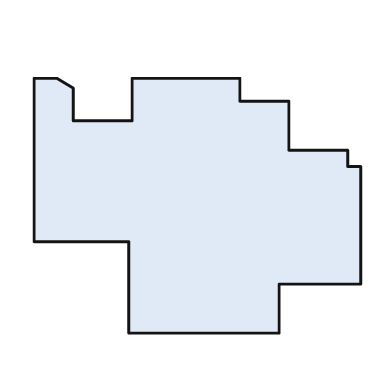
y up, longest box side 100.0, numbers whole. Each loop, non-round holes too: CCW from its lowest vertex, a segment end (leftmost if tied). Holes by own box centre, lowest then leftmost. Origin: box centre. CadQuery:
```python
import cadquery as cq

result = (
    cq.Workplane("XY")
    .moveTo(-21.0, -39.0)
    .lineTo(25.0, -39.0)
    .lineTo(25.0, -24.0)
    .lineTo(50.0, -24.0)
    .lineTo(50.0, 12.0)
    .lineTo(46.0, 12.0)
    .lineTo(46.0, 17.0)
    .lineTo(28.0, 17.0)
    .lineTo(28.0, 32.0)
    .lineTo(13.0, 32.0)
    .lineTo(13.0, 39.0)
    .lineTo(-20.0, 39.0)
    .lineTo(-20.0, 26.0)
    .lineTo(-38.0, 26.0)
    .lineTo(-38.0, 36.0)
    .lineTo(-43.0, 39.0)
    .lineTo(-50.0, 39.0)
    .lineTo(-50.0, -11.0)
    .lineTo(-21.0, -11.0)
    .close()
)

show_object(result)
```